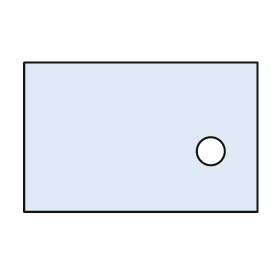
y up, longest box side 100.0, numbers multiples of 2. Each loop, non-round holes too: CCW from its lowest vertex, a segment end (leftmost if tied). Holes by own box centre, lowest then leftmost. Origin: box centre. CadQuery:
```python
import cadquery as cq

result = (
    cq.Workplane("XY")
    .moveTo(-50.0, -32.0)
    .lineTo(50.0, -32.0)
    .lineTo(50.0, 32.0)
    .lineTo(-50.0, 32.0)
    .close()
    .moveTo(30.0, -6.0)
    .circle(6.0)
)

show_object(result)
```